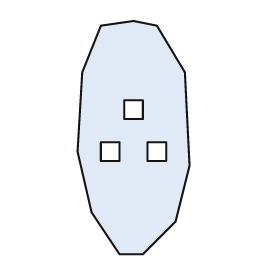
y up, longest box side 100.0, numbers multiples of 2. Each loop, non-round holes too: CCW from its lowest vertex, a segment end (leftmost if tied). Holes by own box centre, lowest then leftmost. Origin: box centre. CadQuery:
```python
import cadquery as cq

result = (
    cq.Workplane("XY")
    .moveTo(-6.0, -50.0)
    .lineTo(4.0, -50.0)
    .lineTo(18.0, -36.0)
    .lineTo(24.0, -12.0)
    .lineTo(22.0, 28.0)
    .lineTo(10.0, 48.0)
    .lineTo(0.0, 50.0)
    .lineTo(-14.0, 48.0)
    .lineTo(-22.0, 28.0)
    .lineTo(-24.0, -6.0)
    .lineTo(-18.0, -32.0)
    .close()
    .moveTo(-14.0, -10.0)
    .lineTo(-6.0, -10.0)
    .lineTo(-6.0, -2.0)
    .lineTo(-14.0, -2.0)
    .close()
    .moveTo(6.0, -10.0)
    .lineTo(14.0, -10.0)
    .lineTo(14.0, -2.0)
    .lineTo(6.0, -2.0)
    .close()
    .moveTo(-4.0, 8.0)
    .lineTo(4.0, 8.0)
    .lineTo(4.0, 16.0)
    .lineTo(-4.0, 16.0)
    .close()
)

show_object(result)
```